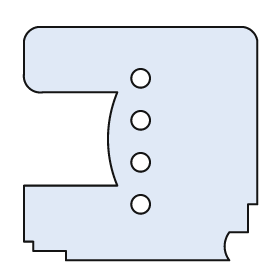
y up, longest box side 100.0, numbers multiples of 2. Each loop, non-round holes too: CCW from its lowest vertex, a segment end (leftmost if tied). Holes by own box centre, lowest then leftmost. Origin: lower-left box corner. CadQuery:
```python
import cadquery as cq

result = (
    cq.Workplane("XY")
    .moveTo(18.0, 0.0)
    .lineTo(88.0, 0.0)
    .threePointArc((86.0, 6.0), (88.0, 12.0))
    .lineTo(96.0, 12.0)
    .lineTo(96.0, 24.0)
    .lineTo(100.0, 24.0)
    .lineTo(100.0, 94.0)
    .threePointArc((98.0, 98.0), (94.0, 100.0))
    .lineTo(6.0, 100.0)
    .threePointArc((2.0, 98.0), (0.0, 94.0))
    .lineTo(0.0, 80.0)
    .threePointArc((2.0, 74.0), (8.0, 72.0))
    .lineTo(40.0, 72.0)
    .threePointArc((36.0, 52.0), (40.0, 32.0))
    .lineTo(0.0, 32.0)
    .lineTo(0.0, 8.0)
    .lineTo(4.0, 8.0)
    .lineTo(4.0, 4.0)
    .lineTo(18.0, 4.0)
    .close()
    .moveTo(50.0, 24.0)
    .circle(4.0)
    .moveTo(50.0, 42.0)
    .circle(4.0)
    .moveTo(50.0, 60.0)
    .circle(4.0)
    .moveTo(50.0, 78.0)
    .circle(4.0)
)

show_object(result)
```